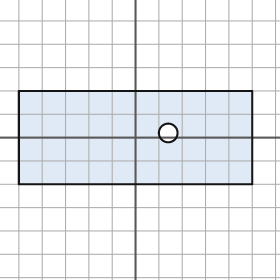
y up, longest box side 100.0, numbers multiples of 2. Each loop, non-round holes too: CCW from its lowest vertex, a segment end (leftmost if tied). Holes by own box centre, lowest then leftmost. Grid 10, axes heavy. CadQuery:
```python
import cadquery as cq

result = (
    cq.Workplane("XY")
    .moveTo(-50.0, -20.0)
    .lineTo(50.0, -20.0)
    .lineTo(50.0, 20.0)
    .lineTo(-50.0, 20.0)
    .close()
    .moveTo(14.0, 2.0)
    .circle(4.0)
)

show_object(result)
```